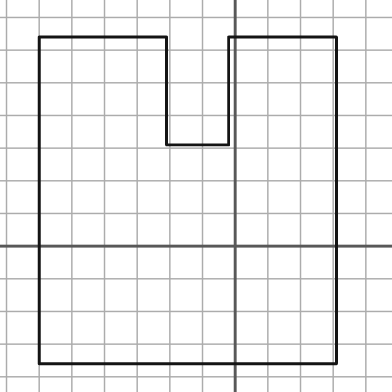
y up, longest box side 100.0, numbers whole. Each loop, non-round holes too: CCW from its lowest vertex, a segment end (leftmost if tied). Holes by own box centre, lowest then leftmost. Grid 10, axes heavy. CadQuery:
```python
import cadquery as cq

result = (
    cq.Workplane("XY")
    .moveTo(-60.0, -36.0)
    .lineTo(31.0, -36.0)
    .lineTo(31.0, 64.0)
    .lineTo(-2.0, 64.0)
    .lineTo(-2.0, 31.0)
    .lineTo(-21.0, 31.0)
    .lineTo(-21.0, 64.0)
    .lineTo(-60.0, 64.0)
    .close()
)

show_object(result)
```